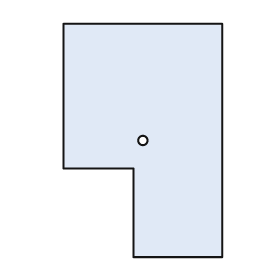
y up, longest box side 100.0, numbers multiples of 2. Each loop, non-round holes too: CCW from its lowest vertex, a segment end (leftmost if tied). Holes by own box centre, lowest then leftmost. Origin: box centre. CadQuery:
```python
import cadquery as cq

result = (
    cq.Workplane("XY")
    .moveTo(-4.0, -50.0)
    .lineTo(34.0, -50.0)
    .lineTo(34.0, 50.0)
    .lineTo(-34.0, 50.0)
    .lineTo(-34.0, -12.0)
    .lineTo(-4.0, -12.0)
    .close()
    .moveTo(0.0, 0.0)
    .circle(2.0)
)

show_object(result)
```